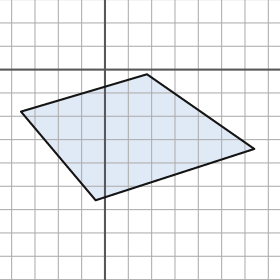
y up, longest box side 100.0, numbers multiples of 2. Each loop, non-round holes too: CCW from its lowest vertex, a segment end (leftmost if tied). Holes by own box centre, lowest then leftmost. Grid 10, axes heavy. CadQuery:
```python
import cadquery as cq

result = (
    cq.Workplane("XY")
    .moveTo(-4.0, -56.0)
    .lineTo(64.0, -34.0)
    .lineTo(18.0, -2.0)
    .lineTo(-36.0, -18.0)
    .close()
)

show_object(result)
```